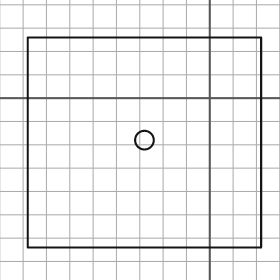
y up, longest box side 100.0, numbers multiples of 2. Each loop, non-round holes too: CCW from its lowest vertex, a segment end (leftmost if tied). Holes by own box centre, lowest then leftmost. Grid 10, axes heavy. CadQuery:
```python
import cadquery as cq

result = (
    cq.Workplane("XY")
    .moveTo(-78.0, -64.0)
    .lineTo(22.0, -64.0)
    .lineTo(22.0, 26.0)
    .lineTo(-78.0, 26.0)
    .close()
    .moveTo(-28.0, -18.0)
    .circle(4.0)
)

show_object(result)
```